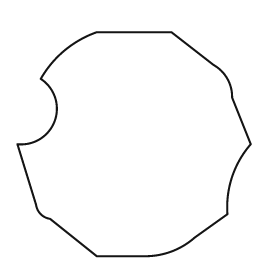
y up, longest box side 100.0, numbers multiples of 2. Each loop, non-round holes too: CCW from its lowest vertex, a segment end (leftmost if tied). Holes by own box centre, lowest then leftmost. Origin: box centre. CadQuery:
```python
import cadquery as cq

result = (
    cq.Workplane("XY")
    .moveTo(-16.0, -48.0)
    .lineTo(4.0, -48.0)
    .threePointArc((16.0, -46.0), (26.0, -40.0))
    .lineTo(40.0, -30.0)
    .threePointArc((42.0, -14.0), (50.0, 0.0))
    .lineTo(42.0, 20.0)
    .threePointArc((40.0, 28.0), (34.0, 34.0))
    .lineTo(16.0, 48.0)
    .lineTo(-16.0, 48.0)
    .threePointArc((-30.0, 40.0), (-40.0, 28.0))
    .threePointArc((-34.0, 10.0), (-50.0, 0.0))
    .lineTo(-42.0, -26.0)
    .threePointArc((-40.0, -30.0), (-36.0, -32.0))
    .close()
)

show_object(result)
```